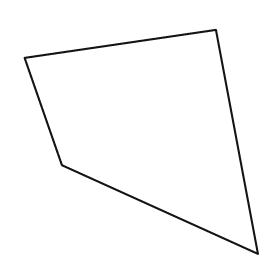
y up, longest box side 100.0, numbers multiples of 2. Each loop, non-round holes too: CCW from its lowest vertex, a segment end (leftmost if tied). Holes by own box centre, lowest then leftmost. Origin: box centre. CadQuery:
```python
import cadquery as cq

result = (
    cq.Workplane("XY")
    .moveTo(50.0, -48.0)
    .lineTo(32.0, 48.0)
    .lineTo(-50.0, 36.0)
    .lineTo(-34.0, -10.0)
    .close()
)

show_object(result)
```